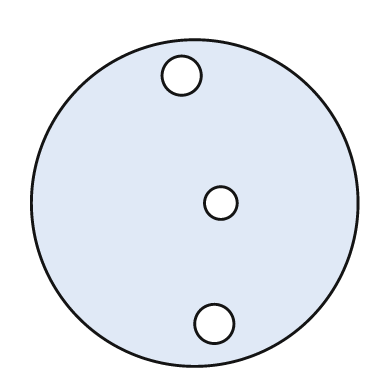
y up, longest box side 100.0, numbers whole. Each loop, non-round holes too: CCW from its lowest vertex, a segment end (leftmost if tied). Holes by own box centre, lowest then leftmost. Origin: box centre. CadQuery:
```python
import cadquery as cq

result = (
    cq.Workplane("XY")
    .moveTo(0.0, 0.0)
    .circle(50.0)
    .moveTo(6.0, -37.0)
    .circle(6.0)
    .moveTo(8.0, 0.0)
    .circle(5.0)
    .moveTo(-4.0, 39.0)
    .circle(6.0)
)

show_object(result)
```